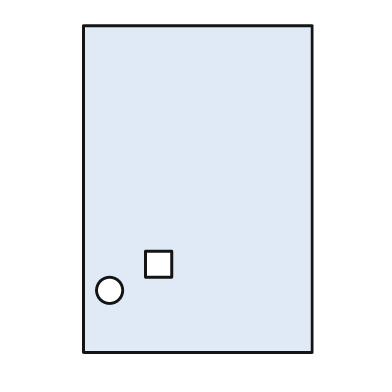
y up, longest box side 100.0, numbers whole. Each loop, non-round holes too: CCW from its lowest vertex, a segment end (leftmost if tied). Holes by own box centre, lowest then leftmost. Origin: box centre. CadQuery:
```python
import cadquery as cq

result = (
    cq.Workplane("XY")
    .moveTo(-35.0, -50.0)
    .lineTo(35.0, -50.0)
    .lineTo(35.0, 50.0)
    .lineTo(-35.0, 50.0)
    .close()
    .moveTo(-27.0, -31.0)
    .circle(4.0)
    .moveTo(-16.0, -27.0)
    .lineTo(-8.0, -27.0)
    .lineTo(-8.0, -19.0)
    .lineTo(-16.0, -19.0)
    .close()
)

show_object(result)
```